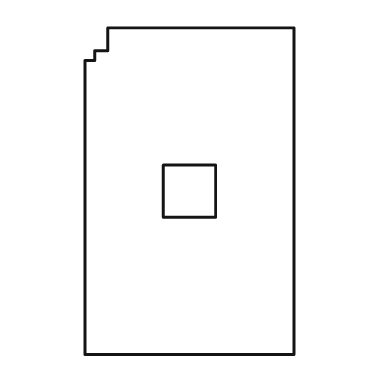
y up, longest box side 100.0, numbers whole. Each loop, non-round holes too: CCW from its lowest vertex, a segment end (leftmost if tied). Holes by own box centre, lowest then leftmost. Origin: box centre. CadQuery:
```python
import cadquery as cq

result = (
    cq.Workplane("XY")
    .moveTo(-32.0, -50.0)
    .lineTo(32.0, -50.0)
    .lineTo(32.0, 50.0)
    .lineTo(-25.0, 50.0)
    .lineTo(-25.0, 43.0)
    .lineTo(-29.0, 43.0)
    .lineTo(-29.0, 40.0)
    .lineTo(-32.0, 40.0)
    .close()
    .moveTo(-8.0, -8.0)
    .lineTo(8.0, -8.0)
    .lineTo(8.0, 8.0)
    .lineTo(-8.0, 8.0)
    .close()
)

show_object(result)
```